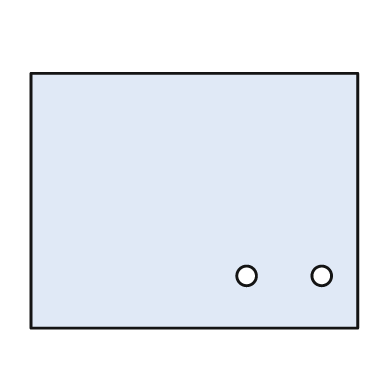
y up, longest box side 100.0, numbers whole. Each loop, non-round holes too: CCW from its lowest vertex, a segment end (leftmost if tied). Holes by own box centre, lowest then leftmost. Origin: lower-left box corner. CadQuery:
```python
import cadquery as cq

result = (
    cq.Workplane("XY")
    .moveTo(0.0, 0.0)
    .lineTo(100.0, 0.0)
    .lineTo(100.0, 78.0)
    .lineTo(0.0, 78.0)
    .close()
    .moveTo(66.0, 16.0)
    .circle(3.0)
    .moveTo(89.0, 16.0)
    .circle(3.0)
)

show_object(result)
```